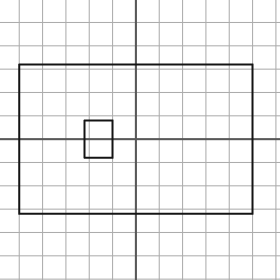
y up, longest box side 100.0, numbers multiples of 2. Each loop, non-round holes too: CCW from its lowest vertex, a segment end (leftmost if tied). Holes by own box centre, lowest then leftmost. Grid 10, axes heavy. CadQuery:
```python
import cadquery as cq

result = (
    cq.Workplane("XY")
    .moveTo(-50.0, -32.0)
    .lineTo(50.0, -32.0)
    .lineTo(50.0, 32.0)
    .lineTo(-50.0, 32.0)
    .close()
    .moveTo(-22.0, -8.0)
    .lineTo(-10.0, -8.0)
    .lineTo(-10.0, 8.0)
    .lineTo(-22.0, 8.0)
    .close()
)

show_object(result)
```